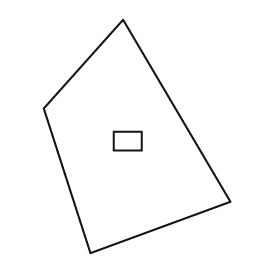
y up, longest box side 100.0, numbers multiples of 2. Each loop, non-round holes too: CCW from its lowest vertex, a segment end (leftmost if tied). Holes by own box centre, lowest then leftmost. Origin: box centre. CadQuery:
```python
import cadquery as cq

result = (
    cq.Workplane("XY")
    .moveTo(-20.0, -50.0)
    .lineTo(40.0, -28.0)
    .lineTo(-6.0, 50.0)
    .lineTo(-40.0, 12.0)
    .close()
    .moveTo(-10.0, -6.0)
    .lineTo(2.0, -6.0)
    .lineTo(2.0, 2.0)
    .lineTo(-10.0, 2.0)
    .close()
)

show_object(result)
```